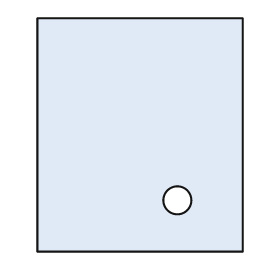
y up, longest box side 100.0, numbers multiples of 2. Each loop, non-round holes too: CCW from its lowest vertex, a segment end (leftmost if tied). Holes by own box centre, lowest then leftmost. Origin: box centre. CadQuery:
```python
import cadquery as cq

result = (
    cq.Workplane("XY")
    .moveTo(-44.0, -50.0)
    .lineTo(44.0, -50.0)
    .lineTo(44.0, 50.0)
    .lineTo(-44.0, 50.0)
    .close()
    .moveTo(16.0, -28.0)
    .circle(6.0)
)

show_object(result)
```